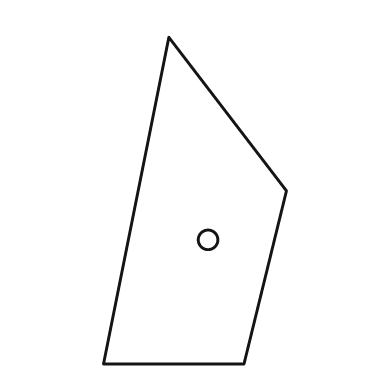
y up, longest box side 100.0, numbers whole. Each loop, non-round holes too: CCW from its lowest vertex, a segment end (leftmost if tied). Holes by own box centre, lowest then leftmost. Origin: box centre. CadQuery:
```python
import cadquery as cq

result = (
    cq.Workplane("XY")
    .moveTo(-28.0, -50.0)
    .lineTo(15.0, -50.0)
    .lineTo(28.0, 3.0)
    .lineTo(-8.0, 50.0)
    .close()
    .moveTo(4.0, -12.0)
    .circle(3.0)
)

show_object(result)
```